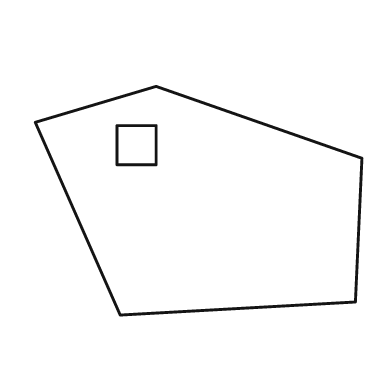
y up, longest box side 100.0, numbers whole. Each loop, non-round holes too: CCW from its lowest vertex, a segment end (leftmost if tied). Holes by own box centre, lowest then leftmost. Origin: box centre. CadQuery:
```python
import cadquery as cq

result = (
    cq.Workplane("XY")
    .moveTo(-24.0, -35.0)
    .lineTo(48.0, -31.0)
    .lineTo(50.0, 13.0)
    .lineTo(-13.0, 35.0)
    .lineTo(-50.0, 24.0)
    .close()
    .moveTo(-25.0, 11.0)
    .lineTo(-13.0, 11.0)
    .lineTo(-13.0, 23.0)
    .lineTo(-25.0, 23.0)
    .close()
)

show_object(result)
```